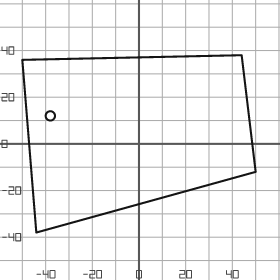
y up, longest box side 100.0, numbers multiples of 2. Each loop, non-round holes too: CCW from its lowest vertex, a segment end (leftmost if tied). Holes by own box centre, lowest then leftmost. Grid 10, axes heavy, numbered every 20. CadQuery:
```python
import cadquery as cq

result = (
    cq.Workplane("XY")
    .moveTo(-44.0, -38.0)
    .lineTo(50.0, -12.0)
    .lineTo(44.0, 38.0)
    .lineTo(-50.0, 36.0)
    .close()
    .moveTo(-38.0, 12.0)
    .circle(2.0)
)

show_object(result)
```